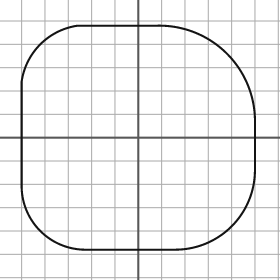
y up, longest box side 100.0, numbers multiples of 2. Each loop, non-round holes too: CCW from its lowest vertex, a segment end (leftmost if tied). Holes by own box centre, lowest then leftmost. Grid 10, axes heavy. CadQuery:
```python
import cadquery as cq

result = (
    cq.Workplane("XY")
    .moveTo(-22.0, -48.0)
    .lineTo(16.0, -48.0)
    .threePointArc((40.0, -38.0), (50.0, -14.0))
    .lineTo(50.0, 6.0)
    .threePointArc((38.0, 36.0), (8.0, 48.0))
    .lineTo(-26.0, 48.0)
    .threePointArc((-42.0, 40.0), (-50.0, 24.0))
    .lineTo(-50.0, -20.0)
    .threePointArc((-42.0, -40.0), (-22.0, -48.0))
    .close()
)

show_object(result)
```